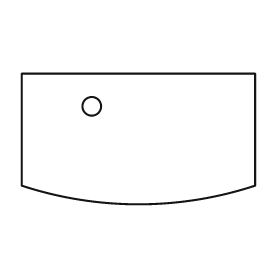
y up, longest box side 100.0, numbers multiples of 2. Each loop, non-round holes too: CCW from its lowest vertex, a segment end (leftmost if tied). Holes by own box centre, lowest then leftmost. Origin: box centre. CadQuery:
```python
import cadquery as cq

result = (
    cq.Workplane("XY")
    .moveTo(-50.0, -20.0)
    .threePointArc((0.0, -28.0), (50.0, -20.0))
    .lineTo(50.0, 28.0)
    .lineTo(-50.0, 28.0)
    .close()
    .moveTo(-20.0, 14.0)
    .circle(4.0)
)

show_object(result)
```